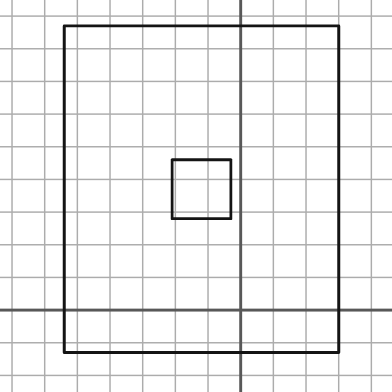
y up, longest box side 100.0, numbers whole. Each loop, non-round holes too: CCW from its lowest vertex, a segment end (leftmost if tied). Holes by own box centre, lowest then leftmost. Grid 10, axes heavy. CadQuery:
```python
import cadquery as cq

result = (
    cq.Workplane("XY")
    .moveTo(-54.0, -13.0)
    .lineTo(30.0, -13.0)
    .lineTo(30.0, 87.0)
    .lineTo(-54.0, 87.0)
    .close()
    .moveTo(-21.0, 28.0)
    .lineTo(-3.0, 28.0)
    .lineTo(-3.0, 46.0)
    .lineTo(-21.0, 46.0)
    .close()
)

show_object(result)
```